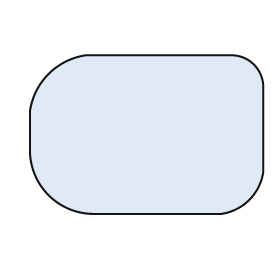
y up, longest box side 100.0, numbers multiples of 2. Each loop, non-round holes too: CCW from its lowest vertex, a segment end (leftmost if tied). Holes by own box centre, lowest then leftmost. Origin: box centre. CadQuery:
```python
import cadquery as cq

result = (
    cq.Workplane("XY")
    .moveTo(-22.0, -34.0)
    .lineTo(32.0, -34.0)
    .threePointArc((44.0, -28.0), (50.0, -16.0))
    .lineTo(50.0, 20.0)
    .threePointArc((46.0, 30.0), (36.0, 34.0))
    .lineTo(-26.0, 34.0)
    .threePointArc((-42.0, 26.0), (-50.0, 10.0))
    .lineTo(-50.0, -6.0)
    .threePointArc((-42.0, -26.0), (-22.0, -34.0))
    .close()
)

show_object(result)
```